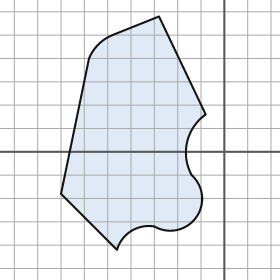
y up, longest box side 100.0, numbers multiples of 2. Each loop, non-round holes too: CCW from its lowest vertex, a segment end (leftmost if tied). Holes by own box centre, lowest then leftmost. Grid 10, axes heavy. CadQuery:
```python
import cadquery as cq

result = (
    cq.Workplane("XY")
    .moveTo(-46.0, -42.0)
    .threePointArc((-40.0, -34.0), (-30.0, -32.0))
    .threePointArc((-12.0, -28.0), (-14.0, -10.0))
    .threePointArc((-16.0, 4.0), (-8.0, 16.0))
    .lineTo(-28.0, 58.0)
    .lineTo(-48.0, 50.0)
    .threePointArc((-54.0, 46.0), (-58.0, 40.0))
    .lineTo(-70.0, -18.0)
    .close()
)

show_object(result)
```